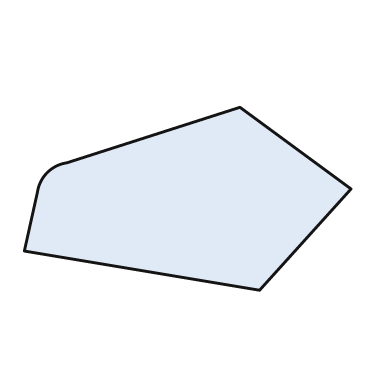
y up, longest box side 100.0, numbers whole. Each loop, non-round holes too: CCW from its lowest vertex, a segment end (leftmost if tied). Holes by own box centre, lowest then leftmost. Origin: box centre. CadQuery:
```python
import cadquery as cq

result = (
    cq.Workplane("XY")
    .moveTo(22.0, -28.0)
    .lineTo(50.0, 3.0)
    .lineTo(16.0, 28.0)
    .lineTo(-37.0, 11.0)
    .threePointArc((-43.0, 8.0), (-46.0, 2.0))
    .lineTo(-50.0, -16.0)
    .close()
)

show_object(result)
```